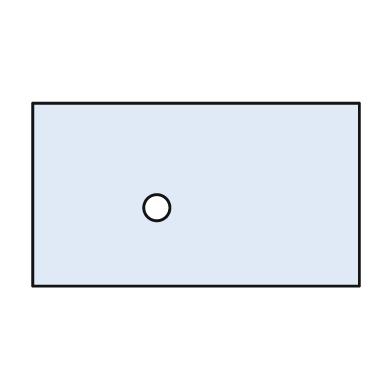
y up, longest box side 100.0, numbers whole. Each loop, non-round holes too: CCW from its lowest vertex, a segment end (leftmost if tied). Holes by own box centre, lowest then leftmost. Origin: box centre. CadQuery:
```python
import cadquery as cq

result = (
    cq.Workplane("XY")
    .moveTo(-50.0, -28.0)
    .lineTo(50.0, -28.0)
    .lineTo(50.0, 28.0)
    .lineTo(-50.0, 28.0)
    .close()
    .moveTo(-12.0, -4.0)
    .circle(4.0)
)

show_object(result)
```